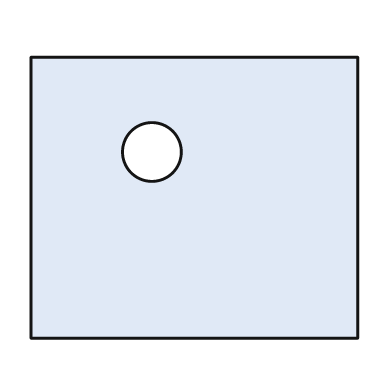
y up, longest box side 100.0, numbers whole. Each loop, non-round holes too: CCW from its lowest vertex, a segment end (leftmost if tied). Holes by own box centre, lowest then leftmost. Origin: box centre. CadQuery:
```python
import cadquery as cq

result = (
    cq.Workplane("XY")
    .moveTo(-50.0, -43.0)
    .lineTo(50.0, -43.0)
    .lineTo(50.0, 43.0)
    .lineTo(-50.0, 43.0)
    .close()
    .moveTo(-13.0, 14.0)
    .circle(9.0)
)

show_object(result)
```